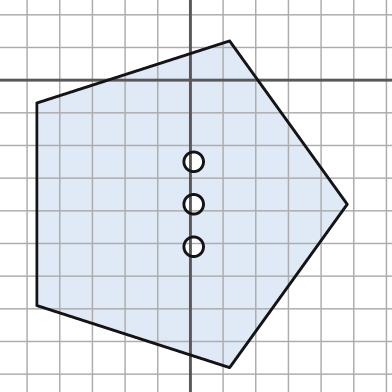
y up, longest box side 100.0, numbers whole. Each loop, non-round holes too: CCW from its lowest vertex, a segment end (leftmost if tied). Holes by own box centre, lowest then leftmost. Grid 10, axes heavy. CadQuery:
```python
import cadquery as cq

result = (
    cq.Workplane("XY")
    .moveTo(12.0, -88.0)
    .lineTo(48.0, -38.0)
    .lineTo(12.0, 12.0)
    .lineTo(-47.0, -7.0)
    .lineTo(-47.0, -69.0)
    .close()
    .moveTo(1.0, -51.0)
    .circle(3.0)
    .moveTo(1.0, -38.0)
    .circle(3.0)
    .moveTo(1.0, -25.0)
    .circle(3.0)
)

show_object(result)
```